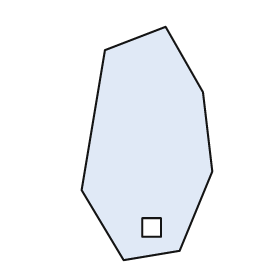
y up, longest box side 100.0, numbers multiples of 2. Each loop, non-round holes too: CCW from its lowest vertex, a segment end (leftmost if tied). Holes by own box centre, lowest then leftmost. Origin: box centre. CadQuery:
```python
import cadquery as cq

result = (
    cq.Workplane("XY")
    .moveTo(-10.0, -50.0)
    .lineTo(14.0, -46.0)
    .lineTo(28.0, -12.0)
    .lineTo(24.0, 22.0)
    .lineTo(8.0, 50.0)
    .lineTo(-18.0, 40.0)
    .lineTo(-28.0, -20.0)
    .close()
    .moveTo(-2.0, -40.0)
    .lineTo(6.0, -40.0)
    .lineTo(6.0, -32.0)
    .lineTo(-2.0, -32.0)
    .close()
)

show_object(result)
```